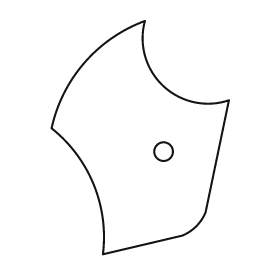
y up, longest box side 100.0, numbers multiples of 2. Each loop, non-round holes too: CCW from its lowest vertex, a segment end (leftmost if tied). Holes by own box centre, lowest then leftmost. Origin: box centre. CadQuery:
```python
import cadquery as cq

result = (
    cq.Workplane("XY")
    .moveTo(-16.0, -50.0)
    .lineTo(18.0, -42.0)
    .threePointArc((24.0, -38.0), (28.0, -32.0))
    .lineTo(38.0, 16.0)
    .threePointArc((10.0, 22.0), (2.0, 50.0))
    .threePointArc((-24.0, 32.0), (-38.0, 4.0))
    .threePointArc((-20.0, -20.0), (-16.0, -50.0))
    .close()
    .moveTo(10.0, -6.0)
    .circle(4.0)
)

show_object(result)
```